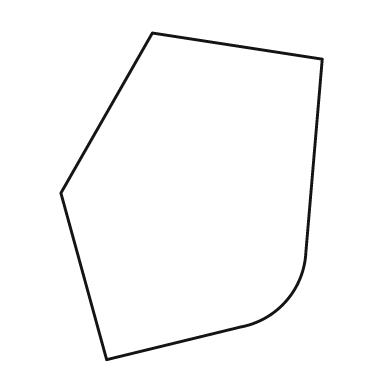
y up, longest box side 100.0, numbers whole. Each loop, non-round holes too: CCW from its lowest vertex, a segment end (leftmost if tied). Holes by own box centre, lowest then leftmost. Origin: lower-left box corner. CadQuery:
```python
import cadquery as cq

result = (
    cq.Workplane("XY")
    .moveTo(14.0, 0.0)
    .lineTo(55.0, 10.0)
    .threePointArc((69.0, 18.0), (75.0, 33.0))
    .lineTo(80.0, 92.0)
    .lineTo(28.0, 100.0)
    .lineTo(0.0, 51.0)
    .close()
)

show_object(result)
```